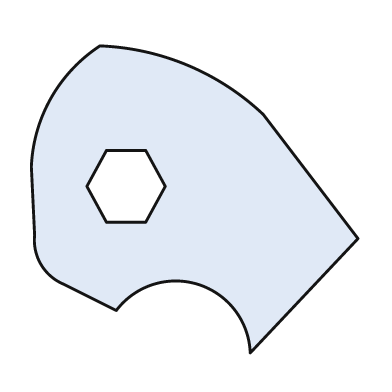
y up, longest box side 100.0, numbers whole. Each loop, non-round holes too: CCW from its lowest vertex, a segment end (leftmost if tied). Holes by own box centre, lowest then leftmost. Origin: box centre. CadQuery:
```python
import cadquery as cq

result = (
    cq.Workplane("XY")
    .moveTo(17.0, -47.0)
    .lineTo(50.0, -12.0)
    .lineTo(21.0, 26.0)
    .threePointArc((-2.0, 41.0), (-29.0, 47.0))
    .threePointArc((-44.0, 31.0), (-50.0, 10.0))
    .lineTo(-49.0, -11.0)
    .threePointArc((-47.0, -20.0), (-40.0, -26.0))
    .lineTo(-24.0, -34.0)
    .threePointArc((1.0, -26.0), (17.0, -47.0))
    .close()
    .moveTo(-27.0, -7.0)
    .lineTo(-15.0, -7.0)
    .lineTo(-9.0, 4.0)
    .lineTo(-15.0, 15.0)
    .lineTo(-27.0, 15.0)
    .lineTo(-33.0, 4.0)
    .close()
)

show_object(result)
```